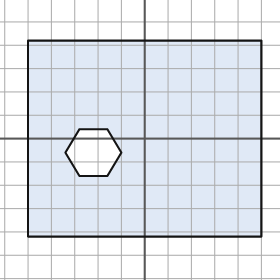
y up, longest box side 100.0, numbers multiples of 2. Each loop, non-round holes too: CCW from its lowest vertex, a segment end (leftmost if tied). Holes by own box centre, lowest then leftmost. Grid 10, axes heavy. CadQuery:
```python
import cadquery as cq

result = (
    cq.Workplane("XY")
    .moveTo(-50.0, -42.0)
    .lineTo(50.0, -42.0)
    .lineTo(50.0, 42.0)
    .lineTo(-50.0, 42.0)
    .close()
    .moveTo(-28.0, -16.0)
    .lineTo(-16.0, -16.0)
    .lineTo(-10.0, -6.0)
    .lineTo(-16.0, 4.0)
    .lineTo(-28.0, 4.0)
    .lineTo(-34.0, -6.0)
    .close()
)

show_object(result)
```